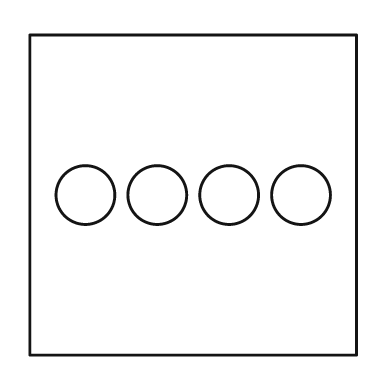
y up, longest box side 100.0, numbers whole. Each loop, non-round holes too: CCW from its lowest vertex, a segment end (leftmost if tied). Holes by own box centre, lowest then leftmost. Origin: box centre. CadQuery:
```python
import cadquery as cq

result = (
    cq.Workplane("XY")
    .moveTo(-50.0, -49.0)
    .lineTo(50.0, -49.0)
    .lineTo(50.0, 49.0)
    .lineTo(-50.0, 49.0)
    .close()
    .moveTo(-33.0, 0.0)
    .circle(9.0)
    .moveTo(-11.0, 0.0)
    .circle(9.0)
    .moveTo(11.0, 0.0)
    .circle(9.0)
    .moveTo(33.0, 0.0)
    .circle(9.0)
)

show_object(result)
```